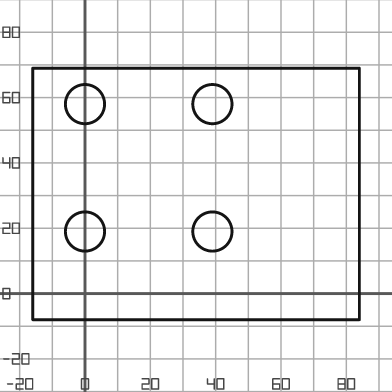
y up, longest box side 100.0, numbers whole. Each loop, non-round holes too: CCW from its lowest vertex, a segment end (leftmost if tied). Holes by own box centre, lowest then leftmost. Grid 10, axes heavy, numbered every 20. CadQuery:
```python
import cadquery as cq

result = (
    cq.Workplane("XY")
    .moveTo(-16.0, -8.0)
    .lineTo(84.0, -8.0)
    .lineTo(84.0, 69.0)
    .lineTo(-16.0, 69.0)
    .close()
    .moveTo(0.0, 19.0)
    .circle(6.0)
    .moveTo(39.0, 19.0)
    .circle(6.0)
    .moveTo(0.0, 58.0)
    .circle(6.0)
    .moveTo(39.0, 58.0)
    .circle(6.0)
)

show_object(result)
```